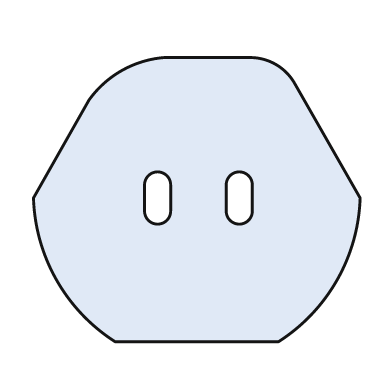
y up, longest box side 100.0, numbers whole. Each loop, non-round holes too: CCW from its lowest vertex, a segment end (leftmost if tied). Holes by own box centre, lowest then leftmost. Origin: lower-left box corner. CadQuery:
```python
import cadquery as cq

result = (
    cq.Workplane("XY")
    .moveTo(25.0, 0.0)
    .lineTo(75.0, 0.0)
    .threePointArc((93.0, 19.0), (100.0, 44.0))
    .lineTo(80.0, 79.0)
    .threePointArc((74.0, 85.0), (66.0, 87.0))
    .lineTo(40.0, 87.0)
    .threePointArc((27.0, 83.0), (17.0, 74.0))
    .lineTo(0.0, 44.0)
    .threePointArc((7.0, 19.0), (25.0, 0.0))
    .close()
    .moveTo(34.0, 40.0)
    .threePointArc((38.0, 36.0), (42.0, 40.0))
    .lineTo(42.0, 48.0)
    .threePointArc((38.0, 52.0), (34.0, 48.0))
    .close()
    .moveTo(59.0, 40.0)
    .threePointArc((63.0, 36.0), (67.0, 40.0))
    .lineTo(67.0, 48.0)
    .threePointArc((63.0, 52.0), (59.0, 48.0))
    .close()
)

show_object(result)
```